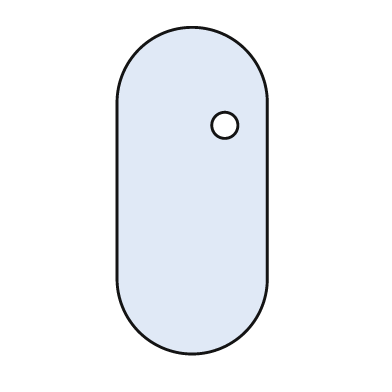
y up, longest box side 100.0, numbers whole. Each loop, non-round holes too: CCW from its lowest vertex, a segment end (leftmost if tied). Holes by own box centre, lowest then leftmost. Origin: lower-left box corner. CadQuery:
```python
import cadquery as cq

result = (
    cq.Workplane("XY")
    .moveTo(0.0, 23.0)
    .threePointArc((23.0, 0.0), (46.0, 23.0))
    .lineTo(46.0, 77.0)
    .threePointArc((23.0, 100.0), (0.0, 77.0))
    .close()
    .moveTo(33.0, 70.0)
    .circle(4.0)
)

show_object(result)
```